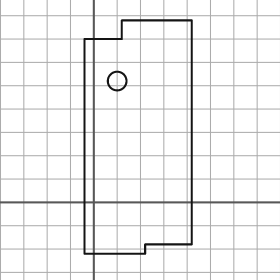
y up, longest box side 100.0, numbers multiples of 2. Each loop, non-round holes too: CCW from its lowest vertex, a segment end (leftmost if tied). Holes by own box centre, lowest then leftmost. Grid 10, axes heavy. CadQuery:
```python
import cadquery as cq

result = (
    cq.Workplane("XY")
    .moveTo(-4.0, -22.0)
    .lineTo(22.0, -22.0)
    .lineTo(22.0, -18.0)
    .lineTo(42.0, -18.0)
    .lineTo(42.0, 78.0)
    .lineTo(12.0, 78.0)
    .lineTo(12.0, 70.0)
    .lineTo(-4.0, 70.0)
    .close()
    .moveTo(10.0, 52.0)
    .circle(4.0)
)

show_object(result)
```